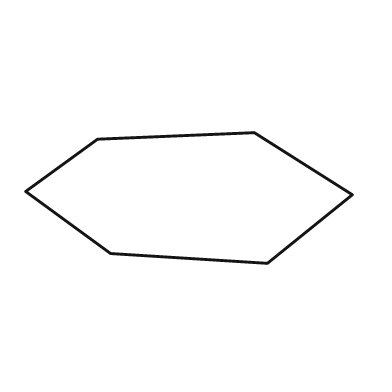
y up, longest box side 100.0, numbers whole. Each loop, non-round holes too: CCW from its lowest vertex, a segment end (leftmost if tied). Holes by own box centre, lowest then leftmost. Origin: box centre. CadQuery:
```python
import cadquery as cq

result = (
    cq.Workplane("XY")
    .moveTo(24.0, -20.0)
    .lineTo(50.0, 1.0)
    .lineTo(20.0, 20.0)
    .lineTo(-28.0, 18.0)
    .lineTo(-50.0, 2.0)
    .lineTo(-24.0, -17.0)
    .close()
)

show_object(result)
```